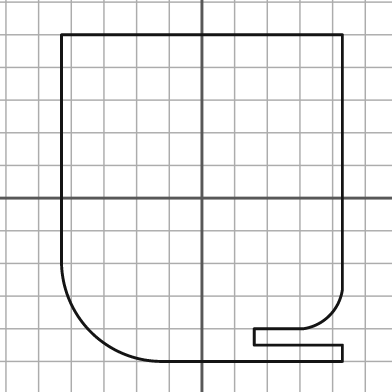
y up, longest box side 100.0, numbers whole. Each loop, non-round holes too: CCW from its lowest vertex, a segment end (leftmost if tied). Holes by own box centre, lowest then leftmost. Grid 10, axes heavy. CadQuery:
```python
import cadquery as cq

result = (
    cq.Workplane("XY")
    .moveTo(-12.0, -50.0)
    .lineTo(43.0, -50.0)
    .lineTo(43.0, -45.0)
    .lineTo(16.0, -45.0)
    .lineTo(16.0, -40.0)
    .lineTo(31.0, -40.0)
    .threePointArc((39.0, -36.0), (43.0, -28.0))
    .lineTo(43.0, 50.0)
    .lineTo(-43.0, 50.0)
    .lineTo(-43.0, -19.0)
    .threePointArc((-34.0, -41.0), (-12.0, -50.0))
    .close()
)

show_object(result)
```